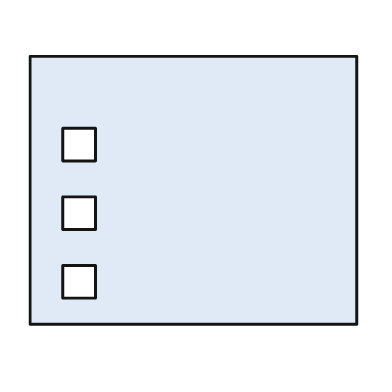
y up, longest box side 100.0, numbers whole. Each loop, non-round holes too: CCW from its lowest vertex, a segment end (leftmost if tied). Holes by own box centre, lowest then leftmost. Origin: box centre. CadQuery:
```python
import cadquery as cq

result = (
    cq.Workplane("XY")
    .moveTo(-50.0, -41.0)
    .lineTo(50.0, -41.0)
    .lineTo(50.0, 41.0)
    .lineTo(-50.0, 41.0)
    .close()
    .moveTo(-40.0, -33.0)
    .lineTo(-30.0, -33.0)
    .lineTo(-30.0, -23.0)
    .lineTo(-40.0, -23.0)
    .close()
    .moveTo(-40.0, -12.0)
    .lineTo(-30.0, -12.0)
    .lineTo(-30.0, -2.0)
    .lineTo(-40.0, -2.0)
    .close()
    .moveTo(-40.0, 9.0)
    .lineTo(-30.0, 9.0)
    .lineTo(-30.0, 19.0)
    .lineTo(-40.0, 19.0)
    .close()
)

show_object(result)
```